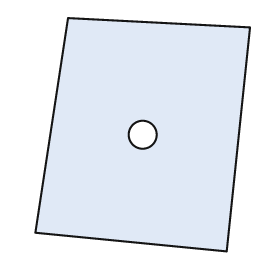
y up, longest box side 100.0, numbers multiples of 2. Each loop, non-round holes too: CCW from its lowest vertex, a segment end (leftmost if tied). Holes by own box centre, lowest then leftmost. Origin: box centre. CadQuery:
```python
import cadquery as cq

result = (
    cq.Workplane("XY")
    .moveTo(36.0, -50.0)
    .lineTo(46.0, 46.0)
    .lineTo(-32.0, 50.0)
    .lineTo(-46.0, -42.0)
    .close()
    .moveTo(0.0, 0.0)
    .circle(6.0)
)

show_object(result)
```